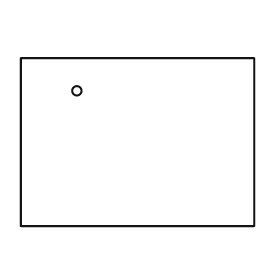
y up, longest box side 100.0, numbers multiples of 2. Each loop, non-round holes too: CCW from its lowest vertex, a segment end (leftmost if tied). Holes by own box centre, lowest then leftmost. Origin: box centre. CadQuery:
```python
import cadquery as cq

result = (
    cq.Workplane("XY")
    .moveTo(-50.0, -36.0)
    .lineTo(50.0, -36.0)
    .lineTo(50.0, 36.0)
    .lineTo(-50.0, 36.0)
    .close()
    .moveTo(-26.0, 22.0)
    .circle(2.0)
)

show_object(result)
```